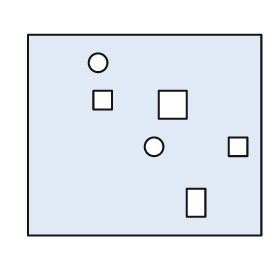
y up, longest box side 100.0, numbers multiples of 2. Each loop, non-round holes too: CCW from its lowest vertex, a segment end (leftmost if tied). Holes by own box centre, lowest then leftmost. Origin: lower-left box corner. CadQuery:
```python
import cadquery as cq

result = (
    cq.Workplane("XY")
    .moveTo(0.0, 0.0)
    .lineTo(100.0, 0.0)
    .lineTo(100.0, 86.0)
    .lineTo(0.0, 86.0)
    .close()
    .moveTo(68.0, 8.0)
    .lineTo(76.0, 8.0)
    .lineTo(76.0, 20.0)
    .lineTo(68.0, 20.0)
    .close()
    .moveTo(54.0, 38.0)
    .circle(4.0)
    .moveTo(86.0, 34.0)
    .lineTo(94.0, 34.0)
    .lineTo(94.0, 42.0)
    .lineTo(86.0, 42.0)
    .close()
    .moveTo(56.0, 50.0)
    .lineTo(68.0, 50.0)
    .lineTo(68.0, 62.0)
    .lineTo(56.0, 62.0)
    .close()
    .moveTo(28.0, 54.0)
    .lineTo(36.0, 54.0)
    .lineTo(36.0, 62.0)
    .lineTo(28.0, 62.0)
    .close()
    .moveTo(30.0, 74.0)
    .circle(4.0)
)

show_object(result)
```